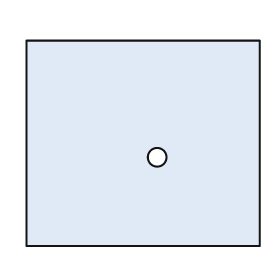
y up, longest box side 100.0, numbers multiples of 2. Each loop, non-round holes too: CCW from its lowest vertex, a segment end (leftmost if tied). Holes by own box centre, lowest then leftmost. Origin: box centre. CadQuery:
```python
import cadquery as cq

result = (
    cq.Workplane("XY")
    .moveTo(-50.0, -44.0)
    .lineTo(50.0, -44.0)
    .lineTo(50.0, 44.0)
    .lineTo(-50.0, 44.0)
    .close()
    .moveTo(6.0, -6.0)
    .circle(4.0)
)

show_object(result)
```